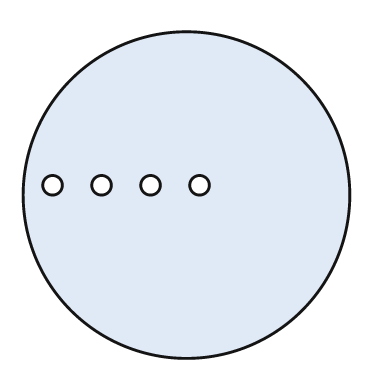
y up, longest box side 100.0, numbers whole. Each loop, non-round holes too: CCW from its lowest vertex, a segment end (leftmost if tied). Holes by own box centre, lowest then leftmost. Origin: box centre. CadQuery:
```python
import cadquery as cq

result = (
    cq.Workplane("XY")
    .moveTo(0.0, 0.0)
    .circle(50.0)
    .moveTo(-41.0, 3.0)
    .circle(3.0)
    .moveTo(-26.0, 3.0)
    .circle(3.0)
    .moveTo(-11.0, 3.0)
    .circle(3.0)
    .moveTo(4.0, 3.0)
    .circle(3.0)
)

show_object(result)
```